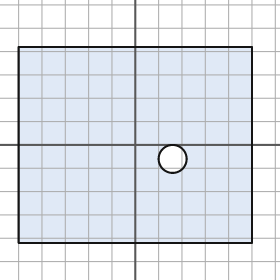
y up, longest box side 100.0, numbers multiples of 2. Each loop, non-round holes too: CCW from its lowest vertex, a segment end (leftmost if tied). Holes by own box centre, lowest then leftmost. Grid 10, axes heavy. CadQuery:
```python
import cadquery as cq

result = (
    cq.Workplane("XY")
    .moveTo(-50.0, -42.0)
    .lineTo(50.0, -42.0)
    .lineTo(50.0, 42.0)
    .lineTo(-50.0, 42.0)
    .close()
    .moveTo(16.0, -6.0)
    .circle(6.0)
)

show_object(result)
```